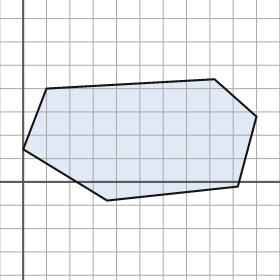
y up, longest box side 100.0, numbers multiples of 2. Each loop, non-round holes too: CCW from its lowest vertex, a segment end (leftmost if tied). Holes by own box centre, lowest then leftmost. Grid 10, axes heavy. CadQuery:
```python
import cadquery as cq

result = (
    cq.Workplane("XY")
    .moveTo(36.0, -8.0)
    .lineTo(92.0, -2.0)
    .lineTo(100.0, 28.0)
    .lineTo(82.0, 44.0)
    .lineTo(10.0, 40.0)
    .lineTo(0.0, 14.0)
    .close()
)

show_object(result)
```